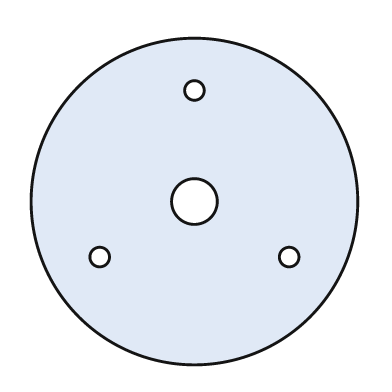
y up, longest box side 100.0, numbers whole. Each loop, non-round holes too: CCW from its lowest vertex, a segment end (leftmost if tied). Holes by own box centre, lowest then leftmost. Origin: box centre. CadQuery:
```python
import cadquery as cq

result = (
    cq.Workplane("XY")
    .moveTo(0.0, 0.0)
    .circle(50.0)
    .moveTo(-29.0, -17.0)
    .circle(3.0)
    .moveTo(29.0, -17.0)
    .circle(3.0)
    .moveTo(0.0, 0.0)
    .circle(7.0)
    .moveTo(0.0, 34.0)
    .circle(3.0)
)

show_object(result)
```